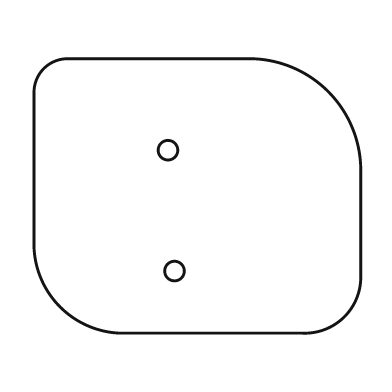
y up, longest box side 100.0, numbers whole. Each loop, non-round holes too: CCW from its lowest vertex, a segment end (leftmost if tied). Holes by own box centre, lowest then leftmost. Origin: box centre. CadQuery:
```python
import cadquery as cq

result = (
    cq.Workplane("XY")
    .moveTo(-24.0, -42.0)
    .lineTo(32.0, -42.0)
    .threePointArc((45.0, -37.0), (50.0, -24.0))
    .lineTo(50.0, 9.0)
    .threePointArc((40.0, 32.0), (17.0, 42.0))
    .lineTo(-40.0, 42.0)
    .threePointArc((-47.0, 39.0), (-50.0, 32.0))
    .lineTo(-50.0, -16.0)
    .threePointArc((-42.0, -34.0), (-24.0, -42.0))
    .close()
    .moveTo(-7.0, -23.0)
    .circle(3.0)
    .moveTo(-9.0, 14.0)
    .circle(3.0)
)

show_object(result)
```